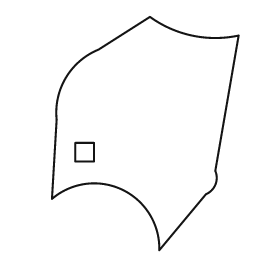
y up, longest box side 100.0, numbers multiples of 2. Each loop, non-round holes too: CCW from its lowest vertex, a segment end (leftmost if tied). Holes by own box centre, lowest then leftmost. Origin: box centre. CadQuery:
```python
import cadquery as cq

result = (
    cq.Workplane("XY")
    .moveTo(6.0, -50.0)
    .lineTo(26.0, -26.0)
    .threePointArc((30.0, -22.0), (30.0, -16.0))
    .lineTo(40.0, 42.0)
    .threePointArc((20.0, 42.0), (2.0, 50.0))
    .lineTo(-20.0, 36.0)
    .threePointArc((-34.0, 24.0), (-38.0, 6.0))
    .lineTo(-40.0, -28.0)
    .threePointArc((-10.0, -24.0), (6.0, -50.0))
    .close()
    .moveTo(-30.0, -12.0)
    .lineTo(-22.0, -12.0)
    .lineTo(-22.0, -4.0)
    .lineTo(-30.0, -4.0)
    .close()
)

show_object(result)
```